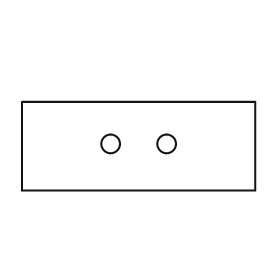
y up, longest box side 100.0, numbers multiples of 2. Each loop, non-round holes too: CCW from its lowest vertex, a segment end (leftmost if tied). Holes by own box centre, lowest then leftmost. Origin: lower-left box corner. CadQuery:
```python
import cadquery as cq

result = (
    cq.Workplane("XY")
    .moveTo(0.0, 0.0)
    .lineTo(100.0, 0.0)
    .lineTo(100.0, 38.0)
    .lineTo(0.0, 38.0)
    .close()
    .moveTo(38.0, 20.0)
    .circle(4.0)
    .moveTo(62.0, 20.0)
    .circle(4.0)
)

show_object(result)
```